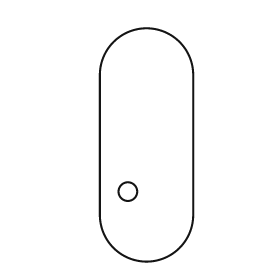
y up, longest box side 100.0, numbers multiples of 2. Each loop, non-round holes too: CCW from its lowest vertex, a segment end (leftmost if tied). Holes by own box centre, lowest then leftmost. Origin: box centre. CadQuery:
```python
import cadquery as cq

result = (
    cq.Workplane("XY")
    .moveTo(-20.0, -30.0)
    .threePointArc((0.0, -50.0), (20.0, -30.0))
    .lineTo(20.0, 30.0)
    .threePointArc((0.0, 50.0), (-20.0, 30.0))
    .close()
    .moveTo(-8.0, -20.0)
    .circle(4.0)
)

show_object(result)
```